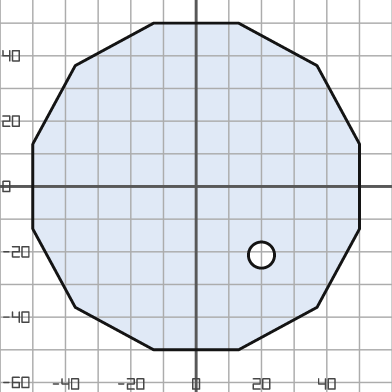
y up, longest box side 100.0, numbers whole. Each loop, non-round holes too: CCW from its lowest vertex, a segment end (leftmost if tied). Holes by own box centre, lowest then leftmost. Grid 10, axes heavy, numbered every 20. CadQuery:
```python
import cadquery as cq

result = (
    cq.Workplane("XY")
    .moveTo(-13.0, -50.0)
    .lineTo(13.0, -50.0)
    .lineTo(37.0, -37.0)
    .lineTo(50.0, -13.0)
    .lineTo(50.0, 13.0)
    .lineTo(37.0, 37.0)
    .lineTo(13.0, 50.0)
    .lineTo(-13.0, 50.0)
    .lineTo(-37.0, 37.0)
    .lineTo(-50.0, 13.0)
    .lineTo(-50.0, -13.0)
    .lineTo(-37.0, -37.0)
    .close()
    .moveTo(20.0, -21.0)
    .circle(4.0)
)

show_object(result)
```